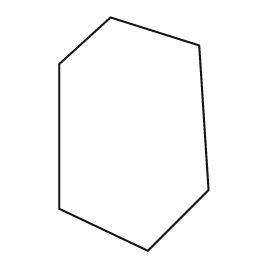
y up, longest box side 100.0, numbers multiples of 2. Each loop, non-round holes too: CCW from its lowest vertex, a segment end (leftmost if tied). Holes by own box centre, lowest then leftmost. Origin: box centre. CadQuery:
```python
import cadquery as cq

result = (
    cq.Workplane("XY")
    .moveTo(6.0, -50.0)
    .lineTo(32.0, -24.0)
    .lineTo(28.0, 38.0)
    .lineTo(-10.0, 50.0)
    .lineTo(-32.0, 30.0)
    .lineTo(-32.0, -32.0)
    .close()
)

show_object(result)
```